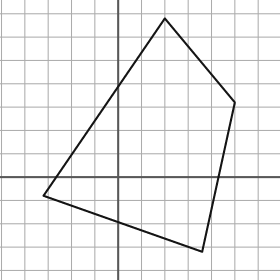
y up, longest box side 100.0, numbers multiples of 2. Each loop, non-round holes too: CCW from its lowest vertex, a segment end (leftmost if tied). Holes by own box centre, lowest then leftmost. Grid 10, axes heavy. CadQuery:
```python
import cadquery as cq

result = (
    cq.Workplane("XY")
    .moveTo(36.0, -32.0)
    .lineTo(50.0, 32.0)
    .lineTo(20.0, 68.0)
    .lineTo(-32.0, -8.0)
    .close()
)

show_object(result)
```